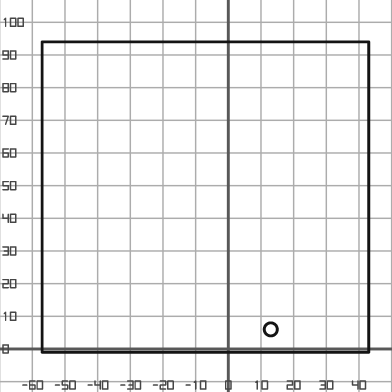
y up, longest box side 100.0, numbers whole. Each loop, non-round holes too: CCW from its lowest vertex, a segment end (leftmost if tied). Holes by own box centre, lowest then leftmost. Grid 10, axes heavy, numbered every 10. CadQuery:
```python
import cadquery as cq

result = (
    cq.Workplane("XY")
    .moveTo(-57.0, -1.0)
    .lineTo(43.0, -1.0)
    .lineTo(43.0, 94.0)
    .lineTo(-57.0, 94.0)
    .close()
    .moveTo(13.0, 6.0)
    .circle(2.0)
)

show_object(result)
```